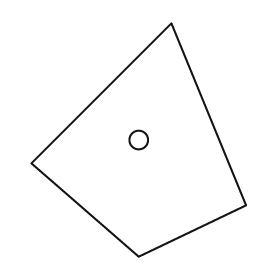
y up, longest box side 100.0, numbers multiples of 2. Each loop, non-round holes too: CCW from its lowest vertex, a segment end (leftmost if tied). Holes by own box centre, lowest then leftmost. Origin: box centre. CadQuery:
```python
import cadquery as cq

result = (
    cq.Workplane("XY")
    .moveTo(0.0, -50.0)
    .lineTo(46.0, -28.0)
    .lineTo(14.0, 50.0)
    .lineTo(-46.0, -10.0)
    .close()
    .moveTo(0.0, 0.0)
    .circle(4.0)
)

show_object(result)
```